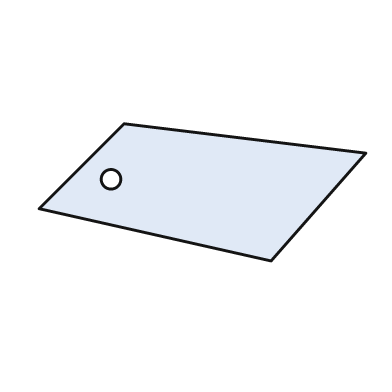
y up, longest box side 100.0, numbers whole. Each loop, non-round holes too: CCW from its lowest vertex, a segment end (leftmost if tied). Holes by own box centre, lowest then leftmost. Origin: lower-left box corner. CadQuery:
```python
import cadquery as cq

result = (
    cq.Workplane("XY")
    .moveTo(71.0, 0.0)
    .lineTo(100.0, 33.0)
    .lineTo(26.0, 42.0)
    .lineTo(0.0, 16.0)
    .close()
    .moveTo(22.0, 25.0)
    .circle(3.0)
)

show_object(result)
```